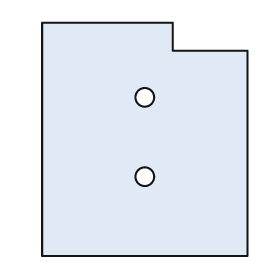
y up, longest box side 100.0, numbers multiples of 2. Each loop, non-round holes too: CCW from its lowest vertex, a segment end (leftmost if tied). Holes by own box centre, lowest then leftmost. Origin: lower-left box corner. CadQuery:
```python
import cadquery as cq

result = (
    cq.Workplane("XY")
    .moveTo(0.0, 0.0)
    .lineTo(88.0, 0.0)
    .lineTo(88.0, 88.0)
    .lineTo(56.0, 88.0)
    .lineTo(56.0, 100.0)
    .lineTo(0.0, 100.0)
    .close()
    .moveTo(44.0, 34.0)
    .circle(4.0)
    .moveTo(44.0, 68.0)
    .circle(4.0)
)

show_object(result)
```